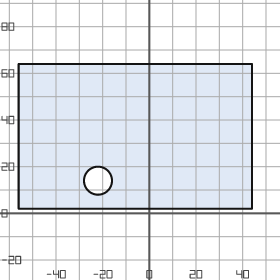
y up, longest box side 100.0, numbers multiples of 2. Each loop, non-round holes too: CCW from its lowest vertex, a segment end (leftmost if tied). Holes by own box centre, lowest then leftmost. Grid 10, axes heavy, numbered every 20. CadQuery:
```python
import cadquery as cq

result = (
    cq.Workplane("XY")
    .moveTo(-56.0, 2.0)
    .lineTo(44.0, 2.0)
    .lineTo(44.0, 64.0)
    .lineTo(-56.0, 64.0)
    .close()
    .moveTo(-22.0, 14.0)
    .circle(6.0)
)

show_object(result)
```